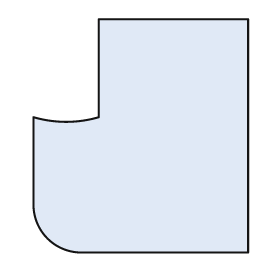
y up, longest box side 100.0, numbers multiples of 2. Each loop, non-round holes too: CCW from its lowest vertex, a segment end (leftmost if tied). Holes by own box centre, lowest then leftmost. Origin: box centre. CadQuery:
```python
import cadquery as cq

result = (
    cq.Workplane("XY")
    .moveTo(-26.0, -50.0)
    .lineTo(46.0, -50.0)
    .lineTo(46.0, 50.0)
    .lineTo(-18.0, 50.0)
    .lineTo(-18.0, 8.0)
    .threePointArc((-32.0, 6.0), (-46.0, 8.0))
    .lineTo(-46.0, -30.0)
    .threePointArc((-40.0, -44.0), (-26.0, -50.0))
    .close()
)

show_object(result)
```